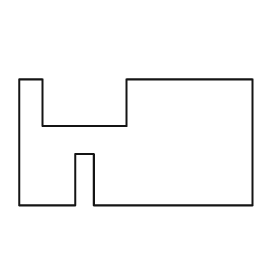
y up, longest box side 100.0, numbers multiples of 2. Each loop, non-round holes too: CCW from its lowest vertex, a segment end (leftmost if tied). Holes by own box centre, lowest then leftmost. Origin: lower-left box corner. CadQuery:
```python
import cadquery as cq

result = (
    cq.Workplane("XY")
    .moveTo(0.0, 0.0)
    .lineTo(24.0, 0.0)
    .lineTo(24.0, 22.0)
    .lineTo(32.0, 22.0)
    .lineTo(32.0, 0.0)
    .lineTo(100.0, 0.0)
    .lineTo(100.0, 54.0)
    .lineTo(46.0, 54.0)
    .lineTo(46.0, 34.0)
    .lineTo(10.0, 34.0)
    .lineTo(10.0, 54.0)
    .lineTo(0.0, 54.0)
    .close()
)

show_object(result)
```